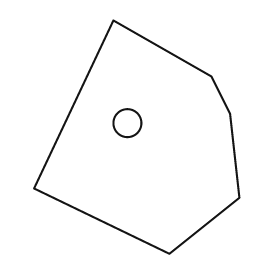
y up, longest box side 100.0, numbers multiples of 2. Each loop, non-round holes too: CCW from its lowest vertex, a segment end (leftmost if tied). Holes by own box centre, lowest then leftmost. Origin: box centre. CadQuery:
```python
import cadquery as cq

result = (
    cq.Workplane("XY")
    .moveTo(14.0, -50.0)
    .lineTo(44.0, -26.0)
    .lineTo(40.0, 10.0)
    .lineTo(32.0, 26.0)
    .lineTo(-10.0, 50.0)
    .lineTo(-44.0, -22.0)
    .close()
    .moveTo(-4.0, 6.0)
    .circle(6.0)
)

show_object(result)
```